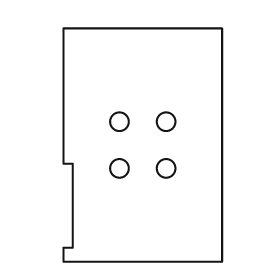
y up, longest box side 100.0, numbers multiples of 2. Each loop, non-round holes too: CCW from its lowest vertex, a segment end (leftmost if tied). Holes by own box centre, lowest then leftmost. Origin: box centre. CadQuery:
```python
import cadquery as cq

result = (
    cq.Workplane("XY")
    .moveTo(-34.0, -50.0)
    .lineTo(34.0, -50.0)
    .lineTo(34.0, 50.0)
    .lineTo(-34.0, 50.0)
    .lineTo(-34.0, -8.0)
    .lineTo(-30.0, -8.0)
    .lineTo(-30.0, -44.0)
    .lineTo(-34.0, -44.0)
    .close()
    .moveTo(-10.0, -10.0)
    .circle(4.0)
    .moveTo(10.0, -10.0)
    .circle(4.0)
    .moveTo(-10.0, 10.0)
    .circle(4.0)
    .moveTo(10.0, 10.0)
    .circle(4.0)
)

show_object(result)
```